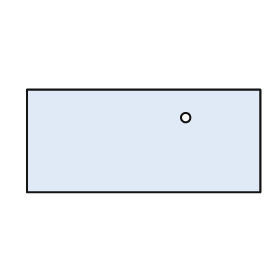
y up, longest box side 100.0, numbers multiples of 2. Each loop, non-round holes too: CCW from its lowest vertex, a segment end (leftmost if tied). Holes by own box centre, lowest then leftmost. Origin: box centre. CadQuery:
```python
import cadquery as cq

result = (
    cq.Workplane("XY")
    .moveTo(-50.0, -22.0)
    .lineTo(50.0, -22.0)
    .lineTo(50.0, 22.0)
    .lineTo(-50.0, 22.0)
    .close()
    .moveTo(18.0, 10.0)
    .circle(2.0)
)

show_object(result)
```